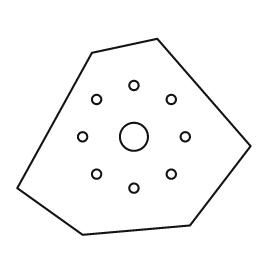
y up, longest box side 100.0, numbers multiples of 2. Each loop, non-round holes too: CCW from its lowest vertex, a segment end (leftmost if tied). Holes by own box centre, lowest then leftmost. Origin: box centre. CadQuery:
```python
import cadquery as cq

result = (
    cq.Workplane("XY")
    .moveTo(-22.0, -42.0)
    .lineTo(24.0, -38.0)
    .lineTo(50.0, -4.0)
    .lineTo(10.0, 42.0)
    .lineTo(-18.0, 36.0)
    .lineTo(-50.0, -22.0)
    .close()
    .moveTo(0.0, -22.0)
    .circle(2.0)
    .moveTo(-16.0, -16.0)
    .circle(2.0)
    .moveTo(16.0, -16.0)
    .circle(2.0)
    .moveTo(-22.0, 0.0)
    .circle(2.0)
    .moveTo(0.0, 0.0)
    .circle(6.0)
    .moveTo(22.0, 0.0)
    .circle(2.0)
    .moveTo(-16.0, 16.0)
    .circle(2.0)
    .moveTo(16.0, 16.0)
    .circle(2.0)
    .moveTo(0.0, 22.0)
    .circle(2.0)
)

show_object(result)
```